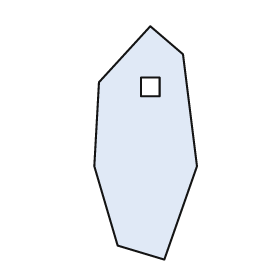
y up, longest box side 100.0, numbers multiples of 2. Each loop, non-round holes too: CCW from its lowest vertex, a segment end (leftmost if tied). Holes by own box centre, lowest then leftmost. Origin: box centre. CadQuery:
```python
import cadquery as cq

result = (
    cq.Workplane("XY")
    .moveTo(8.0, -50.0)
    .lineTo(22.0, -10.0)
    .lineTo(16.0, 38.0)
    .lineTo(2.0, 50.0)
    .lineTo(-20.0, 26.0)
    .lineTo(-22.0, -10.0)
    .lineTo(-12.0, -44.0)
    .close()
    .moveTo(-2.0, 20.0)
    .lineTo(6.0, 20.0)
    .lineTo(6.0, 28.0)
    .lineTo(-2.0, 28.0)
    .close()
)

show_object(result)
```